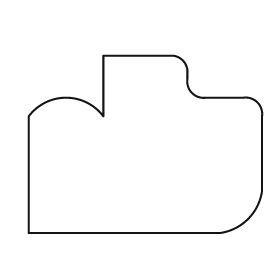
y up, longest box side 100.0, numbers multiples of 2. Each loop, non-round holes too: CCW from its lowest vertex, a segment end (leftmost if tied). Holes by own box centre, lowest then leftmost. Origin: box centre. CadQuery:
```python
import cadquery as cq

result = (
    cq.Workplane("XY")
    .moveTo(-50.0, -38.0)
    .lineTo(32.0, -38.0)
    .threePointArc((44.0, -32.0), (50.0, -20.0))
    .lineTo(50.0, 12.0)
    .threePointArc((48.0, 18.0), (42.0, 20.0))
    .lineTo(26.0, 20.0)
    .threePointArc((20.0, 22.0), (18.0, 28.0))
    .lineTo(18.0, 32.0)
    .threePointArc((16.0, 36.0), (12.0, 38.0))
    .lineTo(-18.0, 38.0)
    .lineTo(-18.0, 12.0)
    .threePointArc((-34.0, 20.0), (-50.0, 12.0))
    .close()
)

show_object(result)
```